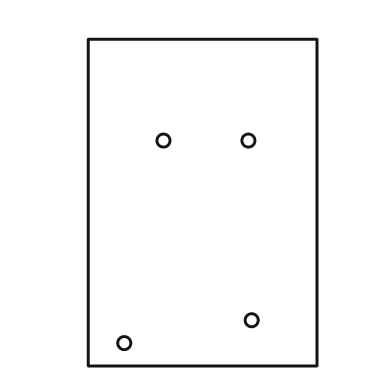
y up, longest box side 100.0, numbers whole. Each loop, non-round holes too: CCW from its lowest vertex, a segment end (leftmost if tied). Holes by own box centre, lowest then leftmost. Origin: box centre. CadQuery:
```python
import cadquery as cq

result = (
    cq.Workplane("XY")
    .moveTo(-35.0, -50.0)
    .lineTo(35.0, -50.0)
    .lineTo(35.0, 50.0)
    .lineTo(-35.0, 50.0)
    .close()
    .moveTo(-24.0, -43.0)
    .circle(2.0)
    .moveTo(15.0, -36.0)
    .circle(2.0)
    .moveTo(-12.0, 19.0)
    .circle(2.0)
    .moveTo(14.0, 19.0)
    .circle(2.0)
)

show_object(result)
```